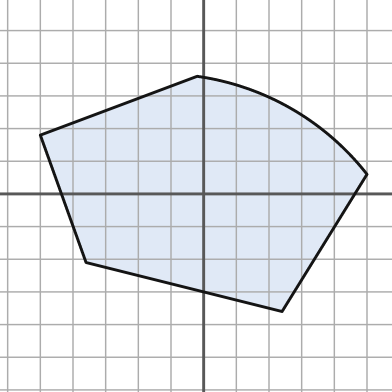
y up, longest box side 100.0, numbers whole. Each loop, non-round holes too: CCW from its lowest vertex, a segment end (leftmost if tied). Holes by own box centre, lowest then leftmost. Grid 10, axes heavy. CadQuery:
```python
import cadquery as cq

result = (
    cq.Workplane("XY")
    .moveTo(24.0, -36.0)
    .lineTo(50.0, 6.0)
    .threePointArc((27.0, 26.0), (-2.0, 36.0))
    .lineTo(-50.0, 18.0)
    .lineTo(-36.0, -21.0)
    .close()
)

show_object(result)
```